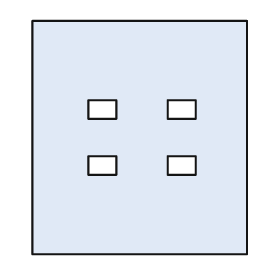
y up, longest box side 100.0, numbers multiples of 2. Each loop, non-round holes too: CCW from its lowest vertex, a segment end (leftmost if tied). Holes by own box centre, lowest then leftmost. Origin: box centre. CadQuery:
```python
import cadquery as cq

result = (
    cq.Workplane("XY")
    .moveTo(-46.0, -50.0)
    .lineTo(46.0, -50.0)
    .lineTo(46.0, 50.0)
    .lineTo(-46.0, 50.0)
    .close()
    .moveTo(-22.0, -16.0)
    .lineTo(-10.0, -16.0)
    .lineTo(-10.0, -8.0)
    .lineTo(-22.0, -8.0)
    .close()
    .moveTo(12.0, -16.0)
    .lineTo(24.0, -16.0)
    .lineTo(24.0, -8.0)
    .lineTo(12.0, -8.0)
    .close()
    .moveTo(-22.0, 8.0)
    .lineTo(-10.0, 8.0)
    .lineTo(-10.0, 16.0)
    .lineTo(-22.0, 16.0)
    .close()
    .moveTo(12.0, 8.0)
    .lineTo(24.0, 8.0)
    .lineTo(24.0, 16.0)
    .lineTo(12.0, 16.0)
    .close()
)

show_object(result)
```